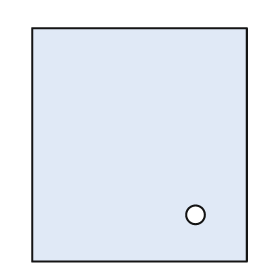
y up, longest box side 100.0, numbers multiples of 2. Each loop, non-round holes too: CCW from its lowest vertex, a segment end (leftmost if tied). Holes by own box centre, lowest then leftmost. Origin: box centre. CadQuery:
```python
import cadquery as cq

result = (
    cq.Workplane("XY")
    .moveTo(-46.0, -50.0)
    .lineTo(46.0, -50.0)
    .lineTo(46.0, 50.0)
    .lineTo(-46.0, 50.0)
    .close()
    .moveTo(24.0, -30.0)
    .circle(4.0)
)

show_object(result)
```